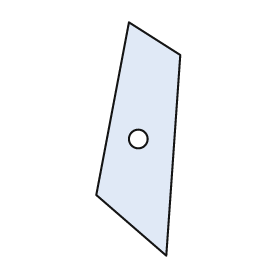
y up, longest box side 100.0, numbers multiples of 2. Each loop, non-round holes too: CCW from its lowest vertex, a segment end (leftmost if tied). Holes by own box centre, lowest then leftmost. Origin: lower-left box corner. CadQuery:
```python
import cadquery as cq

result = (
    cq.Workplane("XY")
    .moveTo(30.0, 0.0)
    .lineTo(36.0, 86.0)
    .lineTo(14.0, 100.0)
    .lineTo(0.0, 26.0)
    .close()
    .moveTo(18.0, 50.0)
    .circle(4.0)
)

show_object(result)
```